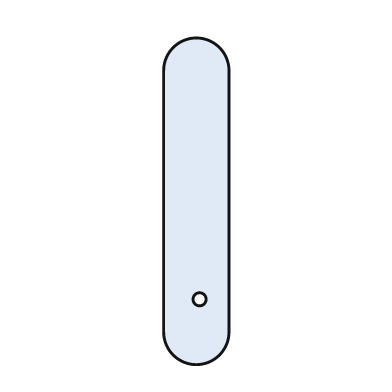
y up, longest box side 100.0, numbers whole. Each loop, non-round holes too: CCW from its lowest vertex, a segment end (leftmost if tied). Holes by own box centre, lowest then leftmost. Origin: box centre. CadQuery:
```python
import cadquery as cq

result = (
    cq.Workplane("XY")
    .moveTo(-10.0, -40.0)
    .threePointArc((0.0, -50.0), (10.0, -40.0))
    .lineTo(10.0, 40.0)
    .threePointArc((0.0, 50.0), (-10.0, 40.0))
    .close()
    .moveTo(1.0, -30.0)
    .circle(2.0)
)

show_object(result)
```